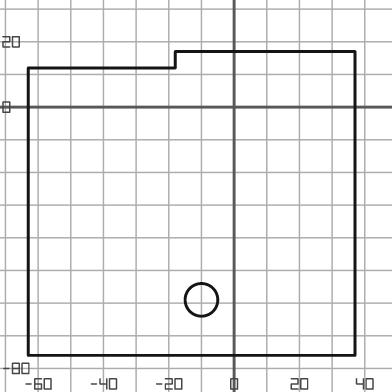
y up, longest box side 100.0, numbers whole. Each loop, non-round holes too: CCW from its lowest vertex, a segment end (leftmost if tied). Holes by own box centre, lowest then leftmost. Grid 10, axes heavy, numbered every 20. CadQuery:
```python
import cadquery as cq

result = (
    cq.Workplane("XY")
    .moveTo(-63.0, -76.0)
    .lineTo(37.0, -76.0)
    .lineTo(37.0, 17.0)
    .lineTo(-18.0, 17.0)
    .lineTo(-18.0, 12.0)
    .lineTo(-63.0, 12.0)
    .close()
    .moveTo(-10.0, -59.0)
    .circle(5.0)
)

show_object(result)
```